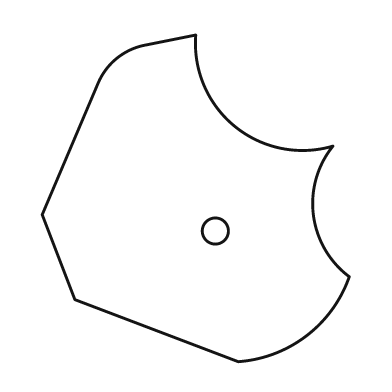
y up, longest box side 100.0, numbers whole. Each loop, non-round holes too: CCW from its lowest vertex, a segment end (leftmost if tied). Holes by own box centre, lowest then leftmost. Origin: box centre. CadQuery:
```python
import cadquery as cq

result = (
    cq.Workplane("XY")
    .moveTo(13.0, -50.0)
    .threePointArc((34.0, -42.0), (47.0, -24.0))
    .threePointArc((36.0, -5.0), (42.0, 16.0))
    .threePointArc((12.0, 22.0), (0.0, 50.0))
    .lineTo(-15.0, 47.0)
    .threePointArc((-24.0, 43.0), (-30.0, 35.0))
    .lineTo(-47.0, -5.0)
    .lineTo(-37.0, -31.0)
    .close()
    .moveTo(6.0, -10.0)
    .circle(4.0)
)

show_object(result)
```